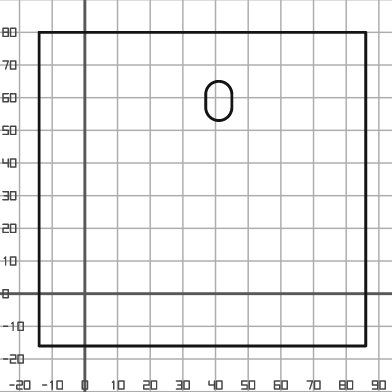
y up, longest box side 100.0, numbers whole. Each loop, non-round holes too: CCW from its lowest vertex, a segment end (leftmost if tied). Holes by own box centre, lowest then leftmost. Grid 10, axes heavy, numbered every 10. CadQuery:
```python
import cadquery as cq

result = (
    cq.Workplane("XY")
    .moveTo(-14.0, -16.0)
    .lineTo(86.0, -16.0)
    .lineTo(86.0, 80.0)
    .lineTo(-14.0, 80.0)
    .close()
    .moveTo(37.0, 57.0)
    .threePointArc((41.0, 53.0), (45.0, 57.0))
    .lineTo(45.0, 61.0)
    .threePointArc((41.0, 65.0), (37.0, 61.0))
    .close()
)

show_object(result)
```